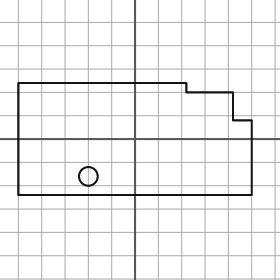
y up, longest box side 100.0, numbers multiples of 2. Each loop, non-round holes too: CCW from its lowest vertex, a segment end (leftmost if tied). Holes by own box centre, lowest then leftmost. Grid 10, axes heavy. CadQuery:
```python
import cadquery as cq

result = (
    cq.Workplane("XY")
    .moveTo(-50.0, -24.0)
    .lineTo(50.0, -24.0)
    .lineTo(50.0, 8.0)
    .lineTo(42.0, 8.0)
    .lineTo(42.0, 20.0)
    .lineTo(22.0, 20.0)
    .lineTo(22.0, 24.0)
    .lineTo(-50.0, 24.0)
    .close()
    .moveTo(-20.0, -16.0)
    .circle(4.0)
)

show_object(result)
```